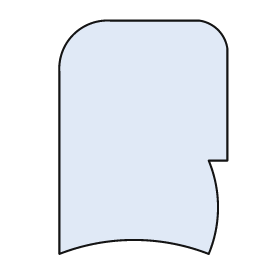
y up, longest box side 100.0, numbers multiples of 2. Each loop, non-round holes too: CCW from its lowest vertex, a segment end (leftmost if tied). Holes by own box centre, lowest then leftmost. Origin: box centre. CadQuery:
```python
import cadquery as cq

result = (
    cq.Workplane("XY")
    .moveTo(-36.0, -50.0)
    .threePointArc((-4.0, -44.0), (28.0, -50.0))
    .threePointArc((32.0, -30.0), (28.0, -10.0))
    .lineTo(36.0, -10.0)
    .lineTo(36.0, 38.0)
    .threePointArc((32.0, 46.0), (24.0, 50.0))
    .lineTo(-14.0, 50.0)
    .threePointArc((-30.0, 44.0), (-36.0, 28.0))
    .close()
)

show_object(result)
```